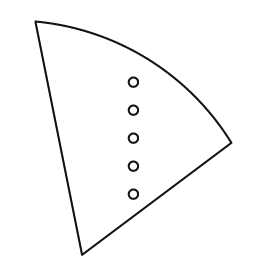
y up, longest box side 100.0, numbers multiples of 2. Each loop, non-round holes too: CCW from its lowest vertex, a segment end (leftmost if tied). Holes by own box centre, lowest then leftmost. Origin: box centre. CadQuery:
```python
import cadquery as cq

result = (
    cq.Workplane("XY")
    .moveTo(-22.0, -50.0)
    .lineTo(42.0, -2.0)
    .threePointArc((6.0, 34.0), (-42.0, 50.0))
    .close()
    .moveTo(0.0, -24.0)
    .circle(2.0)
    .moveTo(0.0, -12.0)
    .circle(2.0)
    .moveTo(0.0, 0.0)
    .circle(2.0)
    .moveTo(0.0, 12.0)
    .circle(2.0)
    .moveTo(0.0, 24.0)
    .circle(2.0)
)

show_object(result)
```